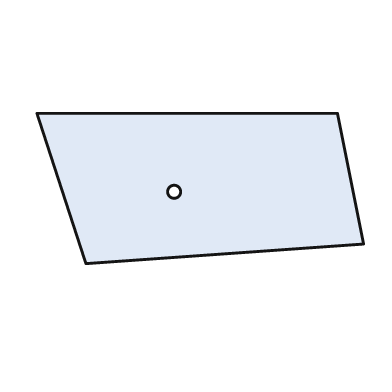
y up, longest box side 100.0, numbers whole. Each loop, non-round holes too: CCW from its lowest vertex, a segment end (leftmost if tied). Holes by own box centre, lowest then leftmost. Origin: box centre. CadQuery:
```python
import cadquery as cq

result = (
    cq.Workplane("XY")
    .moveTo(-35.0, -23.0)
    .lineTo(50.0, -17.0)
    .lineTo(42.0, 23.0)
    .lineTo(-50.0, 23.0)
    .close()
    .moveTo(-8.0, -1.0)
    .circle(2.0)
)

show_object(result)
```